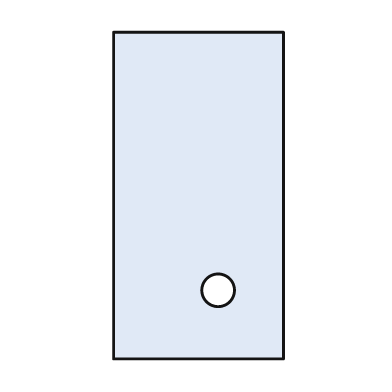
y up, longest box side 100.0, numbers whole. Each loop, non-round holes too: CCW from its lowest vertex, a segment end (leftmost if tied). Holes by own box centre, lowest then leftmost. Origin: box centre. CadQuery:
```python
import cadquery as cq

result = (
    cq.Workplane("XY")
    .moveTo(-26.0, -50.0)
    .lineTo(26.0, -50.0)
    .lineTo(26.0, 50.0)
    .lineTo(-26.0, 50.0)
    .close()
    .moveTo(6.0, -29.0)
    .circle(5.0)
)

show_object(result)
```